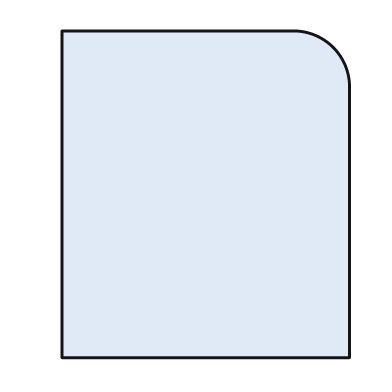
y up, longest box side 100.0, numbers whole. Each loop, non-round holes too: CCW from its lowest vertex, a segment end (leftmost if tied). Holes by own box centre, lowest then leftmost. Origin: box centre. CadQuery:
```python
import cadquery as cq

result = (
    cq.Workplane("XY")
    .moveTo(-44.0, -50.0)
    .lineTo(44.0, -50.0)
    .lineTo(44.0, 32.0)
    .threePointArc((39.0, 45.0), (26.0, 50.0))
    .lineTo(-44.0, 50.0)
    .close()
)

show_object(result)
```